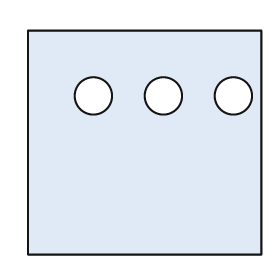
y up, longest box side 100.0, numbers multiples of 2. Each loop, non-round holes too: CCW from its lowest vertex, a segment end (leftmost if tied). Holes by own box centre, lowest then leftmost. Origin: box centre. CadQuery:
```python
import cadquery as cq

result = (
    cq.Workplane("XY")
    .moveTo(-50.0, -48.0)
    .lineTo(50.0, -48.0)
    .lineTo(50.0, 48.0)
    .lineTo(-50.0, 48.0)
    .close()
    .moveTo(-22.0, 20.0)
    .circle(8.0)
    .moveTo(8.0, 20.0)
    .circle(8.0)
    .moveTo(38.0, 20.0)
    .circle(8.0)
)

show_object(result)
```